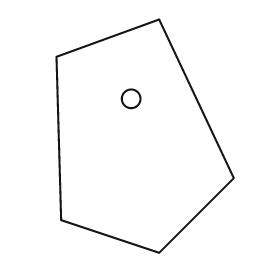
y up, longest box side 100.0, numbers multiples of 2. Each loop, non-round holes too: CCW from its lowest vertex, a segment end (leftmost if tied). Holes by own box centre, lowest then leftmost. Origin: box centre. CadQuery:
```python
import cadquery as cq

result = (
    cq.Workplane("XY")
    .moveTo(6.0, -50.0)
    .lineTo(38.0, -18.0)
    .lineTo(6.0, 50.0)
    .lineTo(-38.0, 34.0)
    .lineTo(-36.0, -36.0)
    .close()
    .moveTo(-6.0, 16.0)
    .circle(4.0)
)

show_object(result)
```